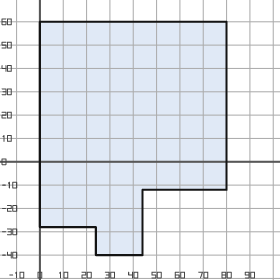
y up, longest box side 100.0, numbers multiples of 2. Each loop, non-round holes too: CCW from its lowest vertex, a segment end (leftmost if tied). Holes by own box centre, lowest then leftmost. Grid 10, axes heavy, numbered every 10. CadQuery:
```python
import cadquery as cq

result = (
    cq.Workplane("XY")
    .moveTo(24.0, -40.0)
    .lineTo(44.0, -40.0)
    .lineTo(44.0, -12.0)
    .lineTo(80.0, -12.0)
    .lineTo(80.0, 60.0)
    .lineTo(0.0, 60.0)
    .lineTo(0.0, -28.0)
    .lineTo(24.0, -28.0)
    .close()
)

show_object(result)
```